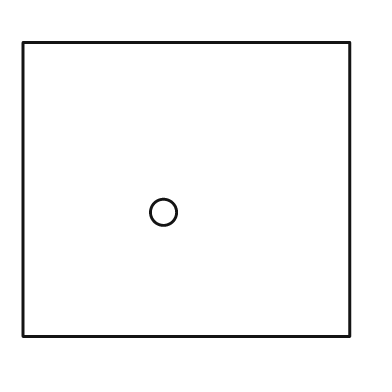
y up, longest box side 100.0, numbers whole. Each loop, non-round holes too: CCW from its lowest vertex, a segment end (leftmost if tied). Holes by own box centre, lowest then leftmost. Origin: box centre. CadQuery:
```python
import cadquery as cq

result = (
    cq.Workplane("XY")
    .moveTo(-50.0, -45.0)
    .lineTo(50.0, -45.0)
    .lineTo(50.0, 45.0)
    .lineTo(-50.0, 45.0)
    .close()
    .moveTo(-7.0, -7.0)
    .circle(4.0)
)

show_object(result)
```